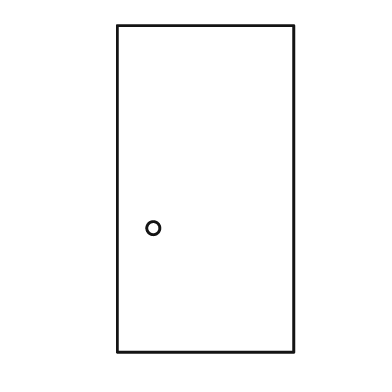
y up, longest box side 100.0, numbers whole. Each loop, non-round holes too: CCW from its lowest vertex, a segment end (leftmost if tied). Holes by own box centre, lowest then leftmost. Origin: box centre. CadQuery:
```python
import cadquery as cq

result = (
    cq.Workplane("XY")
    .moveTo(-27.0, -50.0)
    .lineTo(27.0, -50.0)
    .lineTo(27.0, 50.0)
    .lineTo(-27.0, 50.0)
    .close()
    .moveTo(-16.0, -12.0)
    .circle(2.0)
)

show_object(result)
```